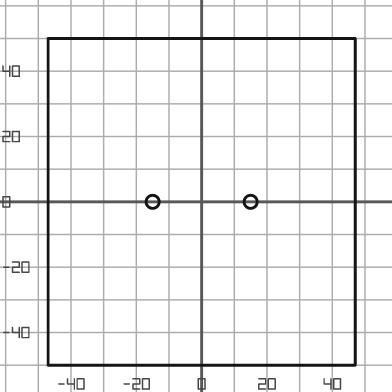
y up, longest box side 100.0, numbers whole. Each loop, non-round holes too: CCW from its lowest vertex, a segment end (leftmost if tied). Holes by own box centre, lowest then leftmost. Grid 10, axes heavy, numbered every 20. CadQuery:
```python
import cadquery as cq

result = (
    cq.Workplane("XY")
    .moveTo(-47.0, -50.0)
    .lineTo(47.0, -50.0)
    .lineTo(47.0, 50.0)
    .lineTo(-47.0, 50.0)
    .close()
    .moveTo(-15.0, 0.0)
    .circle(2.0)
    .moveTo(15.0, 0.0)
    .circle(2.0)
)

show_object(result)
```